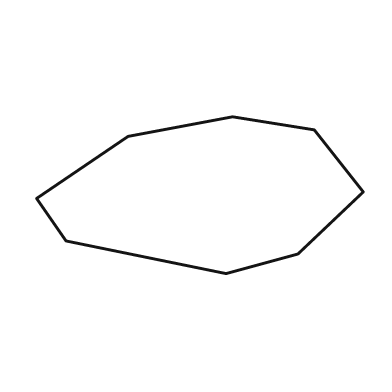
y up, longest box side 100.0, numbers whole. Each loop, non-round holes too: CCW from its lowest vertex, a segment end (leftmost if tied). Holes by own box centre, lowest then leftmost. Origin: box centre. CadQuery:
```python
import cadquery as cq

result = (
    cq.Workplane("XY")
    .moveTo(8.0, -24.0)
    .lineTo(30.0, -18.0)
    .lineTo(50.0, 1.0)
    .lineTo(35.0, 20.0)
    .lineTo(10.0, 24.0)
    .lineTo(-22.0, 18.0)
    .lineTo(-50.0, -1.0)
    .lineTo(-41.0, -14.0)
    .close()
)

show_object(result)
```